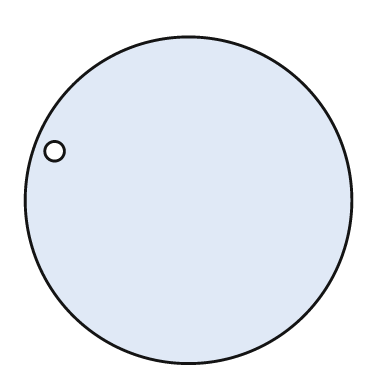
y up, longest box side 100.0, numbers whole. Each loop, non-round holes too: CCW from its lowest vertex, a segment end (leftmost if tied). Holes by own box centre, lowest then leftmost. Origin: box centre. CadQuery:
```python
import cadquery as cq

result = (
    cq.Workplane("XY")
    .moveTo(0.0, 0.0)
    .circle(50.0)
    .moveTo(-41.0, 15.0)
    .circle(3.0)
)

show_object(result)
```